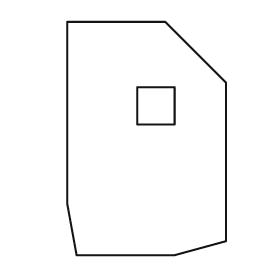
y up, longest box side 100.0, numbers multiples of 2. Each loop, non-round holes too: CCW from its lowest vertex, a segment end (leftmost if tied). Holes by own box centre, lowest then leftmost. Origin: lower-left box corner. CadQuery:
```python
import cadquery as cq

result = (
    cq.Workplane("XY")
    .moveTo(4.0, 0.0)
    .lineTo(46.0, 0.0)
    .lineTo(68.0, 6.0)
    .lineTo(68.0, 74.0)
    .lineTo(42.0, 100.0)
    .lineTo(0.0, 100.0)
    .lineTo(0.0, 22.0)
    .close()
    .moveTo(30.0, 56.0)
    .lineTo(46.0, 56.0)
    .lineTo(46.0, 72.0)
    .lineTo(30.0, 72.0)
    .close()
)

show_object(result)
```